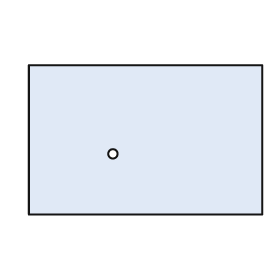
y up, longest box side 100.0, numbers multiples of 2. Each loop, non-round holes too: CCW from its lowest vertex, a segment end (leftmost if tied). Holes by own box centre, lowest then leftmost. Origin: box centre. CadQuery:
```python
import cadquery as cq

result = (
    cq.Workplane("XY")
    .moveTo(-50.0, -32.0)
    .lineTo(50.0, -32.0)
    .lineTo(50.0, 32.0)
    .lineTo(-50.0, 32.0)
    .close()
    .moveTo(-14.0, -6.0)
    .circle(2.0)
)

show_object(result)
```